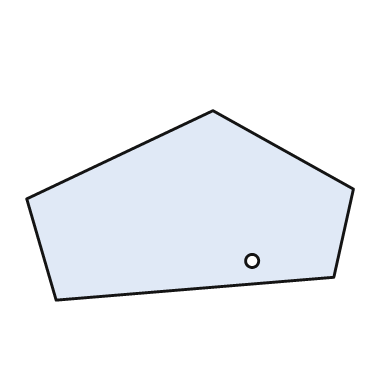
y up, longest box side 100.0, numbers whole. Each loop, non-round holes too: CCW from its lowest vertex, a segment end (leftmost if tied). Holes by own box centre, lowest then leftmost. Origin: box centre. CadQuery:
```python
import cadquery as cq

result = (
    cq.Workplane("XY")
    .moveTo(-41.0, -29.0)
    .lineTo(44.0, -22.0)
    .lineTo(50.0, 5.0)
    .lineTo(7.0, 29.0)
    .lineTo(-50.0, 2.0)
    .close()
    .moveTo(19.0, -17.0)
    .circle(2.0)
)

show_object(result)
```